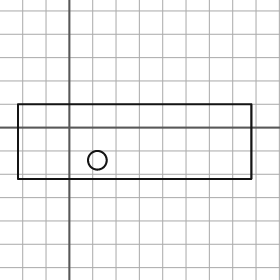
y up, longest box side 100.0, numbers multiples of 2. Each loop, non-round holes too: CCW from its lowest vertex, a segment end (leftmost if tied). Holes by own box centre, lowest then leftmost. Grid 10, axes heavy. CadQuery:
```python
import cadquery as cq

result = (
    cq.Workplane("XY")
    .moveTo(-22.0, -22.0)
    .lineTo(78.0, -22.0)
    .lineTo(78.0, 10.0)
    .lineTo(-22.0, 10.0)
    .close()
    .moveTo(12.0, -14.0)
    .circle(4.0)
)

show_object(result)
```